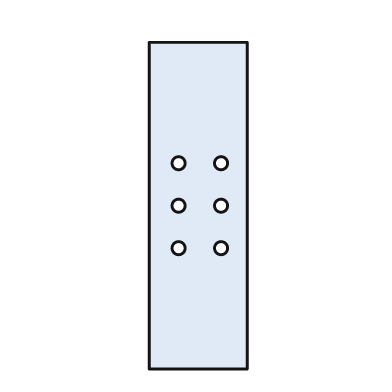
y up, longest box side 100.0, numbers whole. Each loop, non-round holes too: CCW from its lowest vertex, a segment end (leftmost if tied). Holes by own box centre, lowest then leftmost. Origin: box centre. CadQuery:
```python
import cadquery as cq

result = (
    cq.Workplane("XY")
    .moveTo(-15.0, -50.0)
    .lineTo(15.0, -50.0)
    .lineTo(15.0, 50.0)
    .lineTo(-15.0, 50.0)
    .close()
    .moveTo(-6.0, -13.0)
    .circle(2.0)
    .moveTo(7.0, -13.0)
    .circle(2.0)
    .moveTo(-6.0, 0.0)
    .circle(2.0)
    .moveTo(7.0, 0.0)
    .circle(2.0)
    .moveTo(-6.0, 13.0)
    .circle(2.0)
    .moveTo(7.0, 13.0)
    .circle(2.0)
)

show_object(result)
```